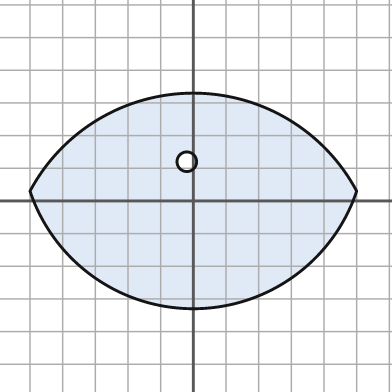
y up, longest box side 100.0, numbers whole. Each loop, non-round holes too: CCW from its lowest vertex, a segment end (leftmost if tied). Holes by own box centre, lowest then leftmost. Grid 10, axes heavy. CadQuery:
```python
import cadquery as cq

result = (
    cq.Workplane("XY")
    .moveTo(-50.0, 3.0)
    .threePointArc((0.0, -33.0), (50.0, 3.0))
    .threePointArc((0.0, 33.0), (-50.0, 3.0))
    .close()
    .moveTo(-2.0, 12.0)
    .circle(3.0)
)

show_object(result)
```